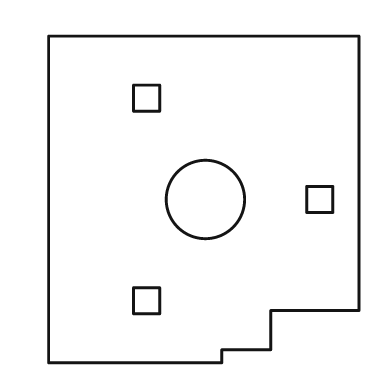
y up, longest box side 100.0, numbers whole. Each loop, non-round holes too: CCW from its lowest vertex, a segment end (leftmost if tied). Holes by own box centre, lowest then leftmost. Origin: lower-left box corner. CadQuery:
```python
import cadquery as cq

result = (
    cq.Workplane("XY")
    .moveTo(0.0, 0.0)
    .lineTo(53.0, 0.0)
    .lineTo(53.0, 4.0)
    .lineTo(68.0, 4.0)
    .lineTo(68.0, 16.0)
    .lineTo(95.0, 16.0)
    .lineTo(95.0, 100.0)
    .lineTo(0.0, 100.0)
    .close()
    .moveTo(26.0, 15.0)
    .lineTo(34.0, 15.0)
    .lineTo(34.0, 23.0)
    .lineTo(26.0, 23.0)
    .close()
    .moveTo(48.0, 50.0)
    .circle(12.0)
    .moveTo(79.0, 46.0)
    .lineTo(87.0, 46.0)
    .lineTo(87.0, 54.0)
    .lineTo(79.0, 54.0)
    .close()
    .moveTo(26.0, 77.0)
    .lineTo(34.0, 77.0)
    .lineTo(34.0, 85.0)
    .lineTo(26.0, 85.0)
    .close()
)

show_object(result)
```